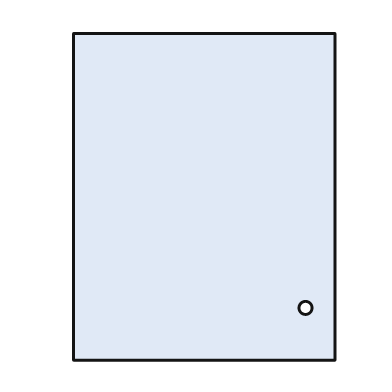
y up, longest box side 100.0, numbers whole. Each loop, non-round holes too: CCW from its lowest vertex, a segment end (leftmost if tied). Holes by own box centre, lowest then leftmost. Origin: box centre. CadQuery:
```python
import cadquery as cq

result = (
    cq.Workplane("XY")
    .moveTo(-40.0, -50.0)
    .lineTo(40.0, -50.0)
    .lineTo(40.0, 50.0)
    .lineTo(-40.0, 50.0)
    .close()
    .moveTo(31.0, -34.0)
    .circle(2.0)
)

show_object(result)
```